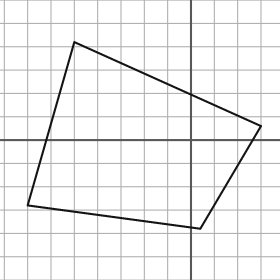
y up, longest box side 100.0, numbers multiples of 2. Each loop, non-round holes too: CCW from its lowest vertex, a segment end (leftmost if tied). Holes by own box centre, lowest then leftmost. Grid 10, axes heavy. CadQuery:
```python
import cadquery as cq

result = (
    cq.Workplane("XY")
    .moveTo(4.0, -38.0)
    .lineTo(30.0, 6.0)
    .lineTo(-50.0, 42.0)
    .lineTo(-70.0, -28.0)
    .close()
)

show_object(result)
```